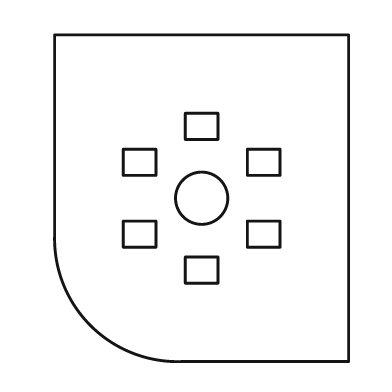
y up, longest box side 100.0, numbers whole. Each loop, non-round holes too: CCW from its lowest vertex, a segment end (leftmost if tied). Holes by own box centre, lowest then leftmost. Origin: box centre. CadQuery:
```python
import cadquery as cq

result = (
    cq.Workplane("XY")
    .moveTo(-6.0, -50.0)
    .lineTo(45.0, -50.0)
    .lineTo(45.0, 50.0)
    .lineTo(-45.0, 50.0)
    .lineTo(-45.0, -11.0)
    .threePointArc((-34.0, -39.0), (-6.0, -50.0))
    .close()
    .moveTo(-5.0, -26.0)
    .lineTo(5.0, -26.0)
    .lineTo(5.0, -18.0)
    .lineTo(-5.0, -18.0)
    .close()
    .moveTo(-24.0, -15.0)
    .lineTo(-14.0, -15.0)
    .lineTo(-14.0, -7.0)
    .lineTo(-24.0, -7.0)
    .close()
    .moveTo(14.0, -15.0)
    .lineTo(24.0, -15.0)
    .lineTo(24.0, -7.0)
    .lineTo(14.0, -7.0)
    .close()
    .moveTo(0.0, 0.0)
    .circle(8.0)
    .moveTo(-24.0, 7.0)
    .lineTo(-14.0, 7.0)
    .lineTo(-14.0, 15.0)
    .lineTo(-24.0, 15.0)
    .close()
    .moveTo(14.0, 7.0)
    .lineTo(24.0, 7.0)
    .lineTo(24.0, 15.0)
    .lineTo(14.0, 15.0)
    .close()
    .moveTo(-5.0, 18.0)
    .lineTo(5.0, 18.0)
    .lineTo(5.0, 26.0)
    .lineTo(-5.0, 26.0)
    .close()
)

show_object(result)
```